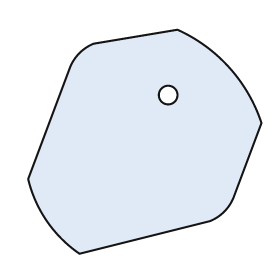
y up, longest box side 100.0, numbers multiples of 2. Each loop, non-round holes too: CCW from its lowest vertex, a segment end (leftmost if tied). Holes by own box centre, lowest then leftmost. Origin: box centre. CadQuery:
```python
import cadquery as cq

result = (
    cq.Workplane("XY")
    .moveTo(-28.0, -48.0)
    .lineTo(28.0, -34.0)
    .threePointArc((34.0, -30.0), (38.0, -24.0))
    .lineTo(50.0, 8.0)
    .threePointArc((36.0, 32.0), (14.0, 48.0))
    .lineTo(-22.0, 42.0)
    .threePointArc((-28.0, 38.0), (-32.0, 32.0))
    .lineTo(-50.0, -16.0)
    .threePointArc((-42.0, -34.0), (-28.0, -48.0))
    .close()
    .moveTo(10.0, 20.0)
    .circle(4.0)
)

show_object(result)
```